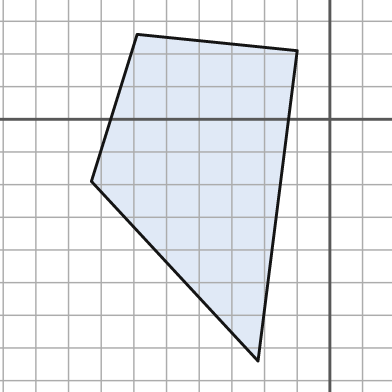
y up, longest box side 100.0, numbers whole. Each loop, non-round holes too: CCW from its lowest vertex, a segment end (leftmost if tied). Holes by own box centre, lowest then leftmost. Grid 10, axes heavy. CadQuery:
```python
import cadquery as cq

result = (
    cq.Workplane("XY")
    .moveTo(-22.0, -74.0)
    .lineTo(-10.0, 21.0)
    .lineTo(-59.0, 26.0)
    .lineTo(-73.0, -19.0)
    .close()
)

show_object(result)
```